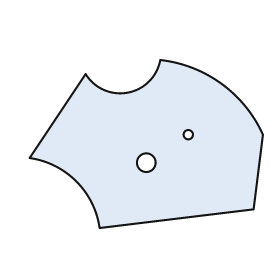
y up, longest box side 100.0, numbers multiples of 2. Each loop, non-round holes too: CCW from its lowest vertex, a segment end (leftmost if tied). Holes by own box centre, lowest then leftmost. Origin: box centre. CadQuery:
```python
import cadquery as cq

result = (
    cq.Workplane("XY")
    .moveTo(-20.0, -36.0)
    .lineTo(46.0, -28.0)
    .lineTo(50.0, 4.0)
    .threePointArc((32.0, 26.0), (6.0, 36.0))
    .threePointArc((-8.0, 22.0), (-26.0, 30.0))
    .lineTo(-50.0, -6.0)
    .threePointArc((-30.0, -16.0), (-20.0, -36.0))
    .close()
    .moveTo(0.0, -8.0)
    .circle(4.0)
    .moveTo(18.0, 4.0)
    .circle(2.0)
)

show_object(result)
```